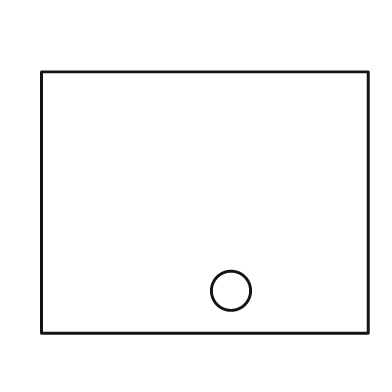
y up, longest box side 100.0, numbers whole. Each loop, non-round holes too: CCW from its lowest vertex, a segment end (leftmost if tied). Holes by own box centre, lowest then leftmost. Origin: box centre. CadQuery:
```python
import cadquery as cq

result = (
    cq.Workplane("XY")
    .moveTo(-50.0, -40.0)
    .lineTo(50.0, -40.0)
    .lineTo(50.0, 40.0)
    .lineTo(-50.0, 40.0)
    .close()
    .moveTo(8.0, -27.0)
    .circle(6.0)
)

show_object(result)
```